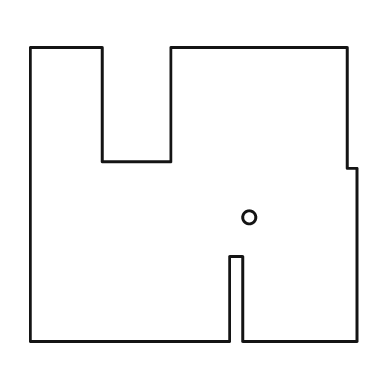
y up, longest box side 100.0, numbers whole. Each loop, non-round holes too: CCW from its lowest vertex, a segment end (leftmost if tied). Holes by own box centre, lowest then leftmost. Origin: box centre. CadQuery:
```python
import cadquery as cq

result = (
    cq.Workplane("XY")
    .moveTo(-50.0, -45.0)
    .lineTo(11.0, -45.0)
    .lineTo(11.0, -19.0)
    .lineTo(15.0, -19.0)
    .lineTo(15.0, -45.0)
    .lineTo(50.0, -45.0)
    .lineTo(50.0, 8.0)
    .lineTo(47.0, 8.0)
    .lineTo(47.0, 45.0)
    .lineTo(-7.0, 45.0)
    .lineTo(-7.0, 10.0)
    .lineTo(-28.0, 10.0)
    .lineTo(-28.0, 45.0)
    .lineTo(-50.0, 45.0)
    .close()
    .moveTo(17.0, -7.0)
    .circle(2.0)
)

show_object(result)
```